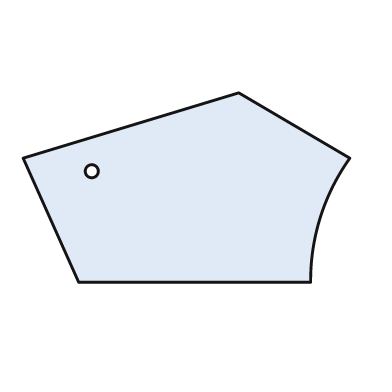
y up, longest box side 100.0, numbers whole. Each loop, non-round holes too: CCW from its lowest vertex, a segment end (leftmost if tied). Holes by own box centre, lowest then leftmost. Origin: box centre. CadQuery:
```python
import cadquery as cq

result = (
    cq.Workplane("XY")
    .moveTo(-33.0, -29.0)
    .lineTo(38.0, -29.0)
    .threePointArc((41.0, -9.0), (50.0, 9.0))
    .lineTo(16.0, 29.0)
    .lineTo(-50.0, 9.0)
    .close()
    .moveTo(-29.0, 5.0)
    .circle(2.0)
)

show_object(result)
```